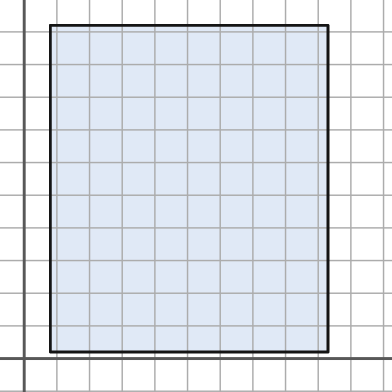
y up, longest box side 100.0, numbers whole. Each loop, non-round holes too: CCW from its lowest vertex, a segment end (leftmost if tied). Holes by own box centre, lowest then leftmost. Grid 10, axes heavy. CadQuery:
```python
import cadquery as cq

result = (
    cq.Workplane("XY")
    .moveTo(8.0, 2.0)
    .lineTo(93.0, 2.0)
    .lineTo(93.0, 102.0)
    .lineTo(8.0, 102.0)
    .close()
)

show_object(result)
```